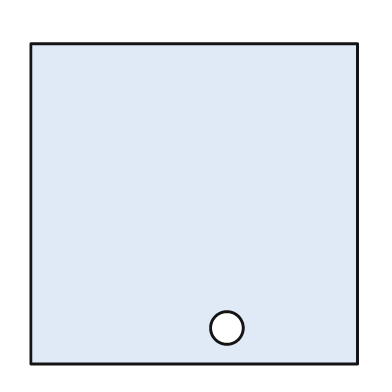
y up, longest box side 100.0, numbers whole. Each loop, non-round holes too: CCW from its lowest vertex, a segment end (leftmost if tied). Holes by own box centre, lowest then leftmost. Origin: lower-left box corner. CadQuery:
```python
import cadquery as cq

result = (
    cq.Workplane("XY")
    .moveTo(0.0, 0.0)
    .lineTo(100.0, 0.0)
    .lineTo(100.0, 98.0)
    .lineTo(0.0, 98.0)
    .close()
    .moveTo(60.0, 11.0)
    .circle(5.0)
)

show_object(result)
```